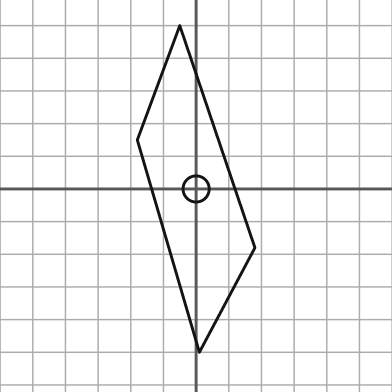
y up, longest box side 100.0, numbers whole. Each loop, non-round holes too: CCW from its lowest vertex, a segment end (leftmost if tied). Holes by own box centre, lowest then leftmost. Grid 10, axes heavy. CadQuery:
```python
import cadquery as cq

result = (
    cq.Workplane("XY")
    .moveTo(1.0, -50.0)
    .lineTo(18.0, -18.0)
    .lineTo(-5.0, 50.0)
    .lineTo(-18.0, 15.0)
    .close()
    .moveTo(0.0, 0.0)
    .circle(4.0)
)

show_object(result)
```